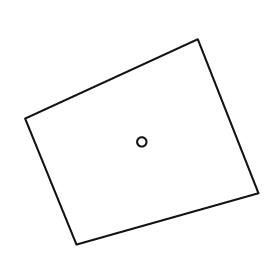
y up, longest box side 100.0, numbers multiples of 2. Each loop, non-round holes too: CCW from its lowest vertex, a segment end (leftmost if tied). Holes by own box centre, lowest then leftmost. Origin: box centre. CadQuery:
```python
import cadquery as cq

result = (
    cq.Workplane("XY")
    .moveTo(-28.0, -44.0)
    .lineTo(50.0, -22.0)
    .lineTo(24.0, 44.0)
    .lineTo(-50.0, 10.0)
    .close()
    .moveTo(0.0, 0.0)
    .circle(2.0)
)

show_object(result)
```